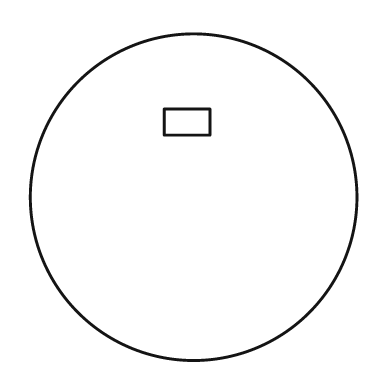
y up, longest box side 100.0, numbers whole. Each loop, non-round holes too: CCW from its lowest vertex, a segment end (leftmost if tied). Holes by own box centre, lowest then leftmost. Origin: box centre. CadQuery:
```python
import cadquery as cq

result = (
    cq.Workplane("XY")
    .moveTo(0.0, 0.0)
    .circle(50.0)
    .moveTo(-9.0, 19.0)
    .lineTo(5.0, 19.0)
    .lineTo(5.0, 27.0)
    .lineTo(-9.0, 27.0)
    .close()
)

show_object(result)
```